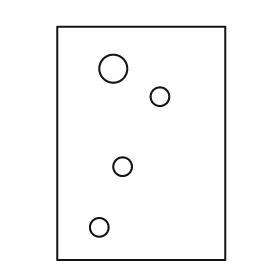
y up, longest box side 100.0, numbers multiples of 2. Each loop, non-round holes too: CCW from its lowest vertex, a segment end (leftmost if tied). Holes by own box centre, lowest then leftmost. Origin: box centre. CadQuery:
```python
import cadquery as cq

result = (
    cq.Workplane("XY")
    .moveTo(-36.0, -50.0)
    .lineTo(36.0, -50.0)
    .lineTo(36.0, 50.0)
    .lineTo(-36.0, 50.0)
    .close()
    .moveTo(-18.0, -36.0)
    .circle(4.0)
    .moveTo(-8.0, -10.0)
    .circle(4.0)
    .moveTo(8.0, 20.0)
    .circle(4.0)
    .moveTo(-12.0, 32.0)
    .circle(6.0)
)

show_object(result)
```